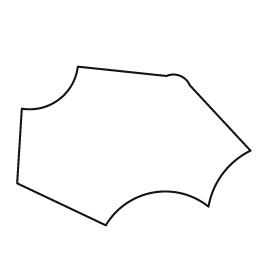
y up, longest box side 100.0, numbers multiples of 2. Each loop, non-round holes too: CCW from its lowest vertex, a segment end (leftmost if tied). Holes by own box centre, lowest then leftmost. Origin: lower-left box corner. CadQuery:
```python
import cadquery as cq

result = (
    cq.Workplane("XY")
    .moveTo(38.0, 0.0)
    .threePointArc((58.0, 14.0), (82.0, 8.0))
    .threePointArc((88.0, 22.0), (100.0, 32.0))
    .lineTo(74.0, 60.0)
    .threePointArc((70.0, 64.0), (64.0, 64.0))
    .lineTo(26.0, 68.0)
    .threePointArc((18.0, 54.0), (2.0, 50.0))
    .lineTo(0.0, 18.0)
    .close()
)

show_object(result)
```